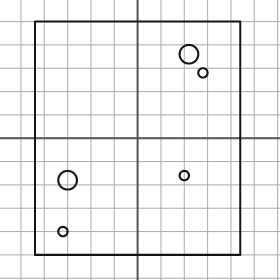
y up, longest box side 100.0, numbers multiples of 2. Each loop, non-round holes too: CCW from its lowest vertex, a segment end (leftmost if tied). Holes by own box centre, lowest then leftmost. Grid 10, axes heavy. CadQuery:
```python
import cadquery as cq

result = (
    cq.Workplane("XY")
    .moveTo(-44.0, -50.0)
    .lineTo(44.0, -50.0)
    .lineTo(44.0, 50.0)
    .lineTo(-44.0, 50.0)
    .close()
    .moveTo(-32.0, -40.0)
    .circle(2.0)
    .moveTo(-30.0, -18.0)
    .circle(4.0)
    .moveTo(20.0, -16.0)
    .circle(2.0)
    .moveTo(28.0, 28.0)
    .circle(2.0)
    .moveTo(22.0, 36.0)
    .circle(4.0)
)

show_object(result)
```